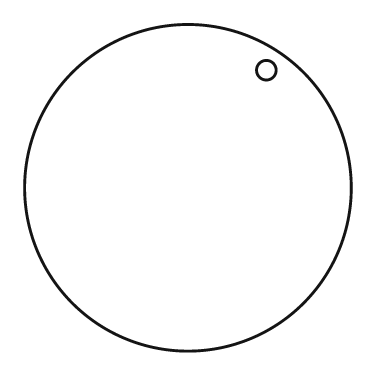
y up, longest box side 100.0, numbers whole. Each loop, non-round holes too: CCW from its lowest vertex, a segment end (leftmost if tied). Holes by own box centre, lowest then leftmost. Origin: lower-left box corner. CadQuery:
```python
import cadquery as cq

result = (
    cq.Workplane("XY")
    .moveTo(50.0, 50.0)
    .circle(50.0)
    .moveTo(74.0, 86.0)
    .circle(3.0)
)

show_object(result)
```